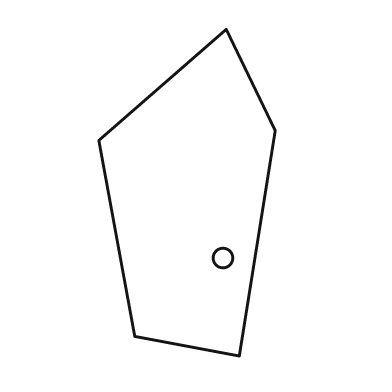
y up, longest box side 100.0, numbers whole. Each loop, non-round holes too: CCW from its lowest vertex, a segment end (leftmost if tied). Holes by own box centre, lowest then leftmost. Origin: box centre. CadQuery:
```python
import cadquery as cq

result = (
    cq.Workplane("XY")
    .moveTo(16.0, -50.0)
    .lineTo(27.0, 19.0)
    .lineTo(12.0, 50.0)
    .lineTo(-27.0, 16.0)
    .lineTo(-16.0, -44.0)
    .close()
    .moveTo(11.0, -20.0)
    .circle(3.0)
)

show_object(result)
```